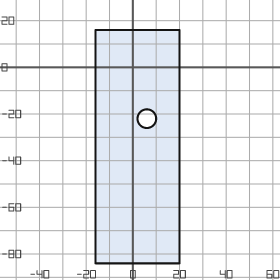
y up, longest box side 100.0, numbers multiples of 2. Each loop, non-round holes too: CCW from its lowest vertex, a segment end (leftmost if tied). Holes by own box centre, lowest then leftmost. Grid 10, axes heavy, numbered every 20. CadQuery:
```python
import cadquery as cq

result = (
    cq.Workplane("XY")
    .moveTo(-16.0, -84.0)
    .lineTo(20.0, -84.0)
    .lineTo(20.0, 16.0)
    .lineTo(-16.0, 16.0)
    .close()
    .moveTo(6.0, -22.0)
    .circle(4.0)
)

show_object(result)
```